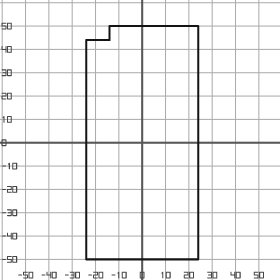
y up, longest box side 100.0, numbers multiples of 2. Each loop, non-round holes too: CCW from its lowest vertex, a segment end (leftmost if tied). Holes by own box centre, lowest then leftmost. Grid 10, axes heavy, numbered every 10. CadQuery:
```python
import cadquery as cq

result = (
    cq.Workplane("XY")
    .moveTo(-24.0, -50.0)
    .lineTo(24.0, -50.0)
    .lineTo(24.0, 50.0)
    .lineTo(-14.0, 50.0)
    .lineTo(-14.0, 44.0)
    .lineTo(-24.0, 44.0)
    .close()
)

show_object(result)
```